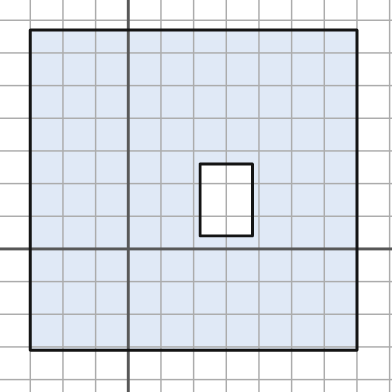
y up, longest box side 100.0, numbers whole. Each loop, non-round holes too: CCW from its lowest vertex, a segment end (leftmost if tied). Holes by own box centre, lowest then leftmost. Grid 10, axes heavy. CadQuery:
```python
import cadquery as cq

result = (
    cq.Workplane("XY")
    .moveTo(-30.0, -31.0)
    .lineTo(70.0, -31.0)
    .lineTo(70.0, 67.0)
    .lineTo(-30.0, 67.0)
    .close()
    .moveTo(22.0, 4.0)
    .lineTo(38.0, 4.0)
    .lineTo(38.0, 26.0)
    .lineTo(22.0, 26.0)
    .close()
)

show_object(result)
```